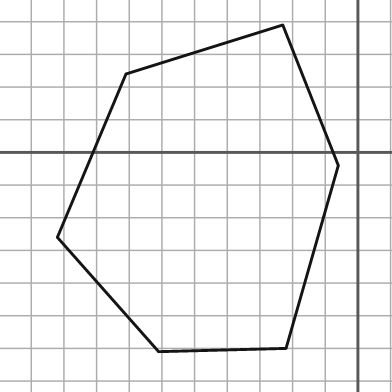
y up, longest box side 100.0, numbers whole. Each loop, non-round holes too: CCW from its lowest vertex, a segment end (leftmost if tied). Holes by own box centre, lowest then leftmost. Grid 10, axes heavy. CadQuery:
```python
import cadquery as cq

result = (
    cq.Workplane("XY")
    .moveTo(-61.0, -61.0)
    .lineTo(-22.0, -60.0)
    .lineTo(-6.0, -4.0)
    .lineTo(-23.0, 39.0)
    .lineTo(-71.0, 24.0)
    .lineTo(-92.0, -26.0)
    .close()
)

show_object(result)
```